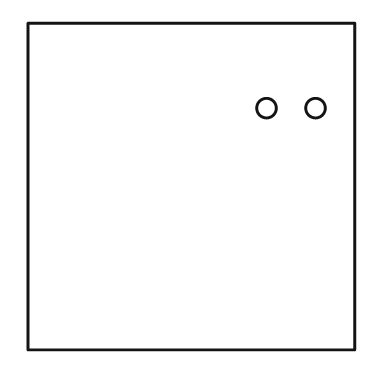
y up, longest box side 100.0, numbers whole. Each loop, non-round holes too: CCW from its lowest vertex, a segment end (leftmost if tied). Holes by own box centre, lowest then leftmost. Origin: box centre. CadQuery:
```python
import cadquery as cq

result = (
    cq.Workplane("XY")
    .moveTo(-50.0, -50.0)
    .lineTo(50.0, -50.0)
    .lineTo(50.0, 50.0)
    .lineTo(-50.0, 50.0)
    .close()
    .moveTo(23.0, 24.0)
    .circle(3.0)
    .moveTo(38.0, 24.0)
    .circle(3.0)
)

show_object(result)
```